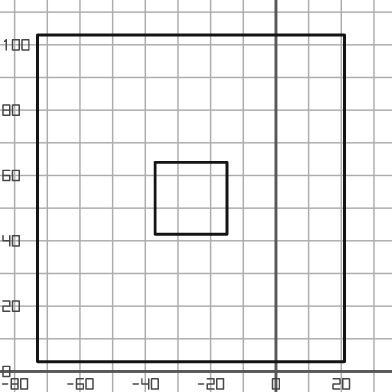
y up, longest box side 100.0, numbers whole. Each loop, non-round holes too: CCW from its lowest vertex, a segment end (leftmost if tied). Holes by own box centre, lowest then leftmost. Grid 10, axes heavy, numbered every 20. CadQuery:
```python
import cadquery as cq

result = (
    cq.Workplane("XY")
    .moveTo(-73.0, 3.0)
    .lineTo(21.0, 3.0)
    .lineTo(21.0, 103.0)
    .lineTo(-73.0, 103.0)
    .close()
    .moveTo(-37.0, 42.0)
    .lineTo(-15.0, 42.0)
    .lineTo(-15.0, 64.0)
    .lineTo(-37.0, 64.0)
    .close()
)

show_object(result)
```